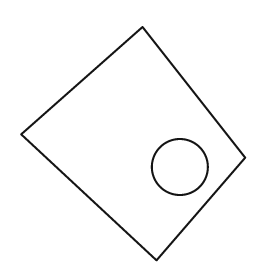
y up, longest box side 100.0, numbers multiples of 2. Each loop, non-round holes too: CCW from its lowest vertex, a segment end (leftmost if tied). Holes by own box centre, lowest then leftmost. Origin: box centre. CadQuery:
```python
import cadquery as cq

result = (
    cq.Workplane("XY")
    .moveTo(10.0, -50.0)
    .lineTo(48.0, -6.0)
    .lineTo(4.0, 50.0)
    .lineTo(-48.0, 4.0)
    .close()
    .moveTo(20.0, -10.0)
    .circle(12.0)
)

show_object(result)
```